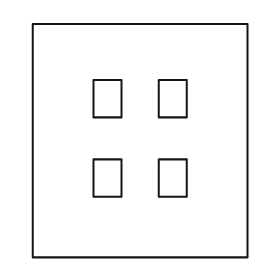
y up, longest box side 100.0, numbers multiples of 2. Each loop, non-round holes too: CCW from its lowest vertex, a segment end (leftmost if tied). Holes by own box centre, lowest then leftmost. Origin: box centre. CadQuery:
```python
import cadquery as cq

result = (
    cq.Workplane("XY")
    .moveTo(-46.0, -50.0)
    .lineTo(46.0, -50.0)
    .lineTo(46.0, 50.0)
    .lineTo(-46.0, 50.0)
    .close()
    .moveTo(-20.0, -24.0)
    .lineTo(-8.0, -24.0)
    .lineTo(-8.0, -8.0)
    .lineTo(-20.0, -8.0)
    .close()
    .moveTo(8.0, -24.0)
    .lineTo(20.0, -24.0)
    .lineTo(20.0, -8.0)
    .lineTo(8.0, -8.0)
    .close()
    .moveTo(-20.0, 10.0)
    .lineTo(-8.0, 10.0)
    .lineTo(-8.0, 26.0)
    .lineTo(-20.0, 26.0)
    .close()
    .moveTo(8.0, 10.0)
    .lineTo(20.0, 10.0)
    .lineTo(20.0, 26.0)
    .lineTo(8.0, 26.0)
    .close()
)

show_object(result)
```